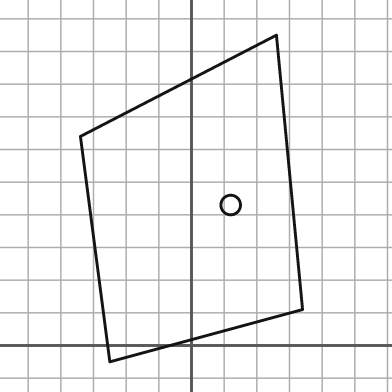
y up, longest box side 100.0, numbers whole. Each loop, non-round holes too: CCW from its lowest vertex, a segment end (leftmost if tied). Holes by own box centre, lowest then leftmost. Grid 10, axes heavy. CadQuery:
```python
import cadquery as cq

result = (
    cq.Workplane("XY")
    .moveTo(-25.0, -5.0)
    .lineTo(34.0, 11.0)
    .lineTo(26.0, 95.0)
    .lineTo(-34.0, 64.0)
    .close()
    .moveTo(12.0, 43.0)
    .circle(3.0)
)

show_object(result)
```